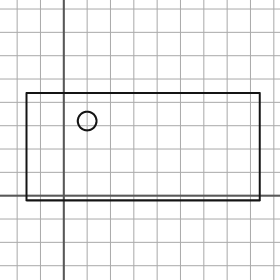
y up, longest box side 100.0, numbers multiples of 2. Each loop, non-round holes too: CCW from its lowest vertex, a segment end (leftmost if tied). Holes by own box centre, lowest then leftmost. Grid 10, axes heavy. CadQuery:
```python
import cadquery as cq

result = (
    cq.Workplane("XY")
    .moveTo(-16.0, -2.0)
    .lineTo(84.0, -2.0)
    .lineTo(84.0, 44.0)
    .lineTo(-16.0, 44.0)
    .close()
    .moveTo(10.0, 32.0)
    .circle(4.0)
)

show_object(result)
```